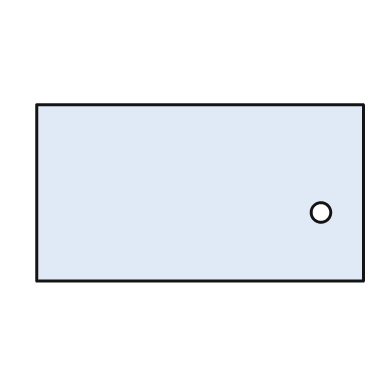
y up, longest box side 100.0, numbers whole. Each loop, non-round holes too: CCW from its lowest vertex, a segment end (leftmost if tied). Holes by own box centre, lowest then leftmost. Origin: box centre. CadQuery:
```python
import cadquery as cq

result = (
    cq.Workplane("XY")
    .moveTo(-50.0, -27.0)
    .lineTo(50.0, -27.0)
    .lineTo(50.0, 27.0)
    .lineTo(-50.0, 27.0)
    .close()
    .moveTo(37.0, -6.0)
    .circle(3.0)
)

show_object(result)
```